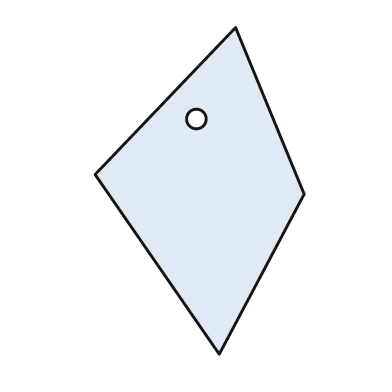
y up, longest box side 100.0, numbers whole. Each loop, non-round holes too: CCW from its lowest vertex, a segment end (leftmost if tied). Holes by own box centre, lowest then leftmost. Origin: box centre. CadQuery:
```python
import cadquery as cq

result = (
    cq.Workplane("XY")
    .moveTo(6.0, -50.0)
    .lineTo(32.0, -1.0)
    .lineTo(11.0, 50.0)
    .lineTo(-32.0, 5.0)
    .close()
    .moveTo(-1.0, 22.0)
    .circle(3.0)
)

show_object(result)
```